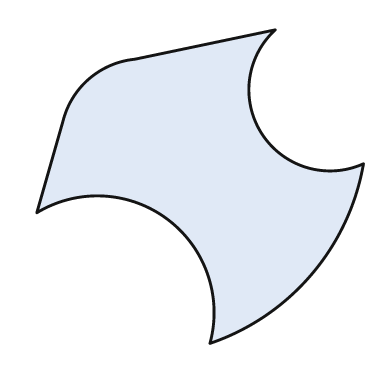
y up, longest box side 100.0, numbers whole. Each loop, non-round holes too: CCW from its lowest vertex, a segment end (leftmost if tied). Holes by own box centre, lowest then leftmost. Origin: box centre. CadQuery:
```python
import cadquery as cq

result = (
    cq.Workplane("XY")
    .moveTo(3.0, -48.0)
    .threePointArc((34.0, -27.0), (50.0, 7.0))
    .threePointArc((19.0, 16.0), (23.0, 48.0))
    .lineTo(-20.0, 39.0)
    .threePointArc((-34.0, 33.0), (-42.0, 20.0))
    .lineTo(-50.0, -8.0)
    .threePointArc((-10.0, -10.0), (3.0, -48.0))
    .close()
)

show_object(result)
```